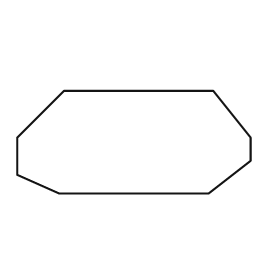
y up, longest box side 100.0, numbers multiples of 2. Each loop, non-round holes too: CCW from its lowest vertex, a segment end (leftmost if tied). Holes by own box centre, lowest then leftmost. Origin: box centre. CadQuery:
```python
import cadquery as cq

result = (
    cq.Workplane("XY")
    .moveTo(-32.0, -22.0)
    .lineTo(32.0, -22.0)
    .lineTo(50.0, -8.0)
    .lineTo(50.0, 2.0)
    .lineTo(34.0, 22.0)
    .lineTo(-30.0, 22.0)
    .lineTo(-50.0, 2.0)
    .lineTo(-50.0, -14.0)
    .close()
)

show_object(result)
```